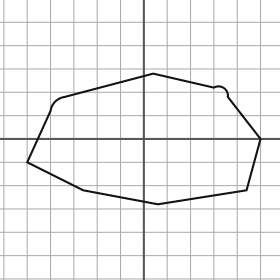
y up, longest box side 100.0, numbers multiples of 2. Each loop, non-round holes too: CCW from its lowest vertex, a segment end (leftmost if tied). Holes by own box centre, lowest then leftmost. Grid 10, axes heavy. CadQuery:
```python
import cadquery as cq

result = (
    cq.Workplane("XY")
    .moveTo(6.0, -28.0)
    .lineTo(44.0, -22.0)
    .lineTo(50.0, 0.0)
    .lineTo(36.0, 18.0)
    .threePointArc((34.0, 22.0), (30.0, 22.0))
    .lineTo(4.0, 28.0)
    .lineTo(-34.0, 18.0)
    .threePointArc((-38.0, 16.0), (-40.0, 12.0))
    .lineTo(-50.0, -10.0)
    .lineTo(-26.0, -22.0)
    .close()
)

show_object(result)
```